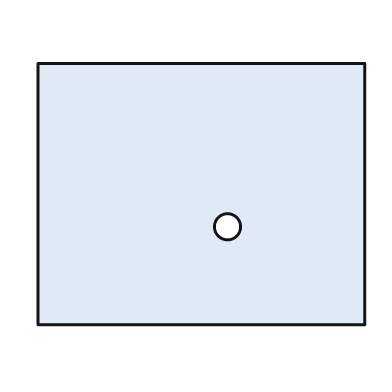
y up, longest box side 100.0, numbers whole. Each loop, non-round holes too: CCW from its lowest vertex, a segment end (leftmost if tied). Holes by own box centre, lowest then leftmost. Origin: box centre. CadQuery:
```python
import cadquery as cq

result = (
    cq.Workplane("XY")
    .moveTo(-50.0, -40.0)
    .lineTo(50.0, -40.0)
    .lineTo(50.0, 40.0)
    .lineTo(-50.0, 40.0)
    .close()
    .moveTo(8.0, -10.0)
    .circle(4.0)
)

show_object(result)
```